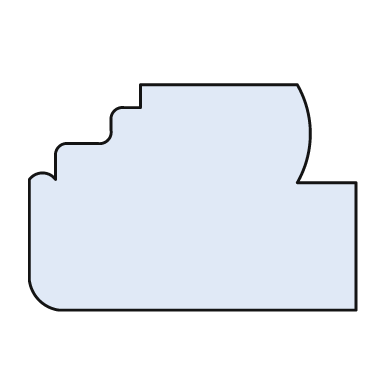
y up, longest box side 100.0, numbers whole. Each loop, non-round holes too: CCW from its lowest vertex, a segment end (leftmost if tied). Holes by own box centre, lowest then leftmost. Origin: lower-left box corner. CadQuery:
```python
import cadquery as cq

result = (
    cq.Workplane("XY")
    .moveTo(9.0, 0.0)
    .lineTo(100.0, 0.0)
    .lineTo(100.0, 39.0)
    .lineTo(82.0, 39.0)
    .threePointArc((86.0, 54.0), (82.0, 69.0))
    .lineTo(34.0, 69.0)
    .lineTo(34.0, 62.0)
    .lineTo(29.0, 62.0)
    .threePointArc((26.0, 61.0), (25.0, 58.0))
    .lineTo(25.0, 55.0)
    .threePointArc((24.0, 52.0), (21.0, 51.0))
    .lineTo(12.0, 51.0)
    .threePointArc((9.0, 50.0), (8.0, 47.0))
    .lineTo(8.0, 40.0)
    .threePointArc((4.0, 42.0), (0.0, 40.0))
    .lineTo(0.0, 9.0)
    .threePointArc((3.0, 3.0), (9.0, 0.0))
    .close()
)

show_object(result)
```